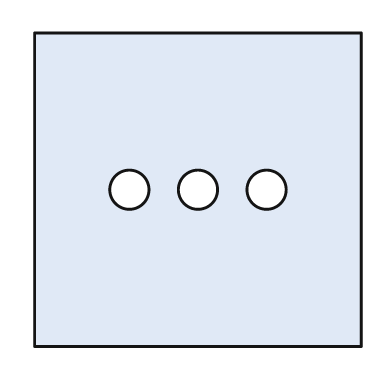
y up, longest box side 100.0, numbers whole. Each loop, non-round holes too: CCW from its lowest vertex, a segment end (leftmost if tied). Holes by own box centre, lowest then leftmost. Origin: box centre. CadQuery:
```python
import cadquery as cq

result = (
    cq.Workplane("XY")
    .moveTo(-50.0, -48.0)
    .lineTo(50.0, -48.0)
    .lineTo(50.0, 48.0)
    .lineTo(-50.0, 48.0)
    .close()
    .moveTo(-21.0, 0.0)
    .circle(6.0)
    .moveTo(0.0, 0.0)
    .circle(6.0)
    .moveTo(21.0, 0.0)
    .circle(6.0)
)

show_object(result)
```